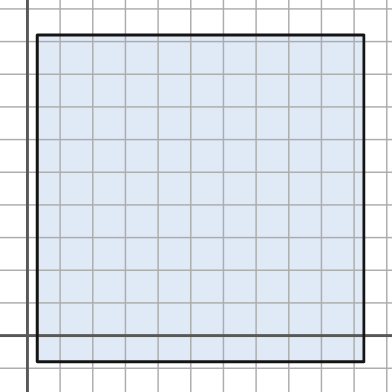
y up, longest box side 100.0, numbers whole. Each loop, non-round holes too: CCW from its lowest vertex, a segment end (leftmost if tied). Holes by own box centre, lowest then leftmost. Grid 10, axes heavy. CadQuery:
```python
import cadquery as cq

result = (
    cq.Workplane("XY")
    .moveTo(3.0, -8.0)
    .lineTo(103.0, -8.0)
    .lineTo(103.0, 92.0)
    .lineTo(3.0, 92.0)
    .close()
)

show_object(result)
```